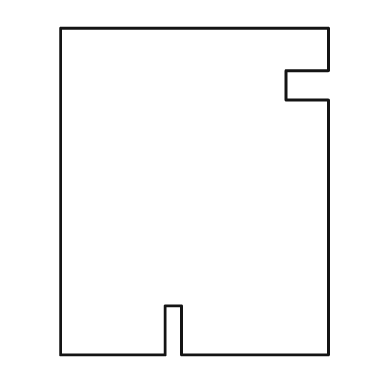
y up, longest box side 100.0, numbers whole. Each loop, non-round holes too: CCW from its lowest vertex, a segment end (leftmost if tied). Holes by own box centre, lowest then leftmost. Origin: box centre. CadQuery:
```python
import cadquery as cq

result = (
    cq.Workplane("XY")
    .moveTo(-41.0, -50.0)
    .lineTo(-9.0, -50.0)
    .lineTo(-9.0, -35.0)
    .lineTo(-4.0, -35.0)
    .lineTo(-4.0, -50.0)
    .lineTo(41.0, -50.0)
    .lineTo(41.0, 28.0)
    .lineTo(28.0, 28.0)
    .lineTo(28.0, 37.0)
    .lineTo(41.0, 37.0)
    .lineTo(41.0, 50.0)
    .lineTo(-41.0, 50.0)
    .close()
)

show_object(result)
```